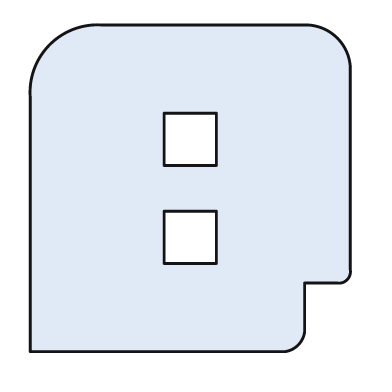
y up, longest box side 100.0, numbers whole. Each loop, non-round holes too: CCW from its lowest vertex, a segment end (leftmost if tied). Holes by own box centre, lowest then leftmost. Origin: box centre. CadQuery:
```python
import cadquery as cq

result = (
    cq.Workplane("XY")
    .moveTo(-49.0, -50.0)
    .lineTo(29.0, -50.0)
    .threePointArc((33.0, -48.0), (35.0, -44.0))
    .lineTo(35.0, -29.0)
    .lineTo(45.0, -29.0)
    .threePointArc((48.0, -28.0), (49.0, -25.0))
    .lineTo(49.0, 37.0)
    .threePointArc((45.0, 46.0), (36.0, 50.0))
    .lineTo(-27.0, 50.0)
    .threePointArc((-43.0, 44.0), (-49.0, 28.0))
    .close()
    .moveTo(-8.0, -23.0)
    .lineTo(8.0, -23.0)
    .lineTo(8.0, -7.0)
    .lineTo(-8.0, -7.0)
    .close()
    .moveTo(-8.0, 7.0)
    .lineTo(8.0, 7.0)
    .lineTo(8.0, 23.0)
    .lineTo(-8.0, 23.0)
    .close()
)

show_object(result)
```